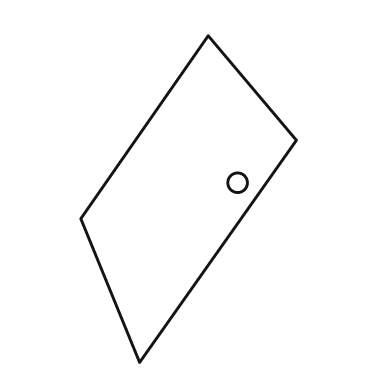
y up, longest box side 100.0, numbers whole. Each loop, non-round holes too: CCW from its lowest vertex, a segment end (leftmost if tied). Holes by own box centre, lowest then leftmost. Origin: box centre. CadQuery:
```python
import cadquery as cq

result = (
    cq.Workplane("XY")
    .moveTo(-15.0, -50.0)
    .lineTo(33.0, 18.0)
    .lineTo(6.0, 50.0)
    .lineTo(-33.0, -6.0)
    .close()
    .moveTo(15.0, 5.0)
    .circle(3.0)
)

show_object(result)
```